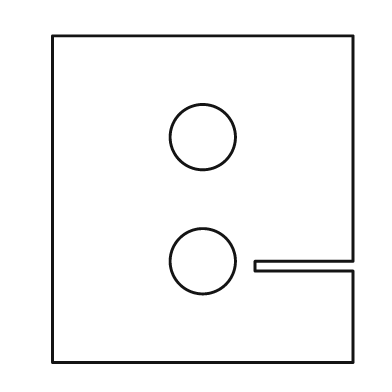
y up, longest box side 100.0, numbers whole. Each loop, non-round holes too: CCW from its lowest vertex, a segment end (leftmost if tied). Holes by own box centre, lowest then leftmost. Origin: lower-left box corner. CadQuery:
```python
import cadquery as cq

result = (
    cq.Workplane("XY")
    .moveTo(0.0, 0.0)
    .lineTo(92.0, 0.0)
    .lineTo(92.0, 28.0)
    .lineTo(62.0, 28.0)
    .lineTo(62.0, 31.0)
    .lineTo(92.0, 31.0)
    .lineTo(92.0, 100.0)
    .lineTo(0.0, 100.0)
    .close()
    .moveTo(46.0, 31.0)
    .circle(10.0)
    .moveTo(46.0, 69.0)
    .circle(10.0)
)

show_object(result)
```